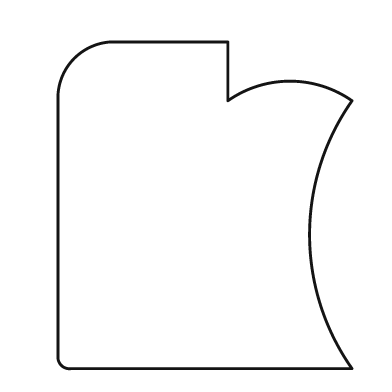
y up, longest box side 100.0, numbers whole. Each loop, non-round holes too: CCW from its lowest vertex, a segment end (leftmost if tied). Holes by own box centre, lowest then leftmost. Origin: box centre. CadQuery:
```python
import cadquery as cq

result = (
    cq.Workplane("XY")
    .moveTo(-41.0, -50.0)
    .lineTo(45.0, -50.0)
    .threePointArc((32.0, -9.0), (45.0, 32.0))
    .threePointArc((26.0, 38.0), (7.0, 32.0))
    .lineTo(7.0, 50.0)
    .lineTo(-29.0, 50.0)
    .threePointArc((-40.0, 45.0), (-45.0, 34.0))
    .lineTo(-45.0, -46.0)
    .threePointArc((-44.0, -49.0), (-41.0, -50.0))
    .close()
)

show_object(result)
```